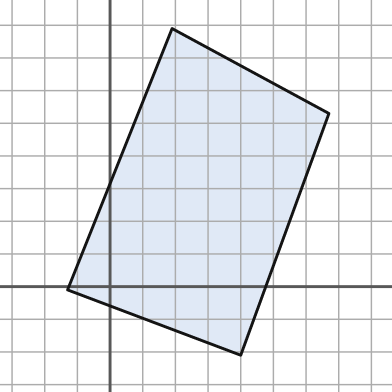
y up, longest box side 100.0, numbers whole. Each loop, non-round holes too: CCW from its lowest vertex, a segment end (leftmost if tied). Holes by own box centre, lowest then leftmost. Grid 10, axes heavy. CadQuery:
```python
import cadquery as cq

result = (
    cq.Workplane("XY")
    .moveTo(40.0, -21.0)
    .lineTo(67.0, 53.0)
    .lineTo(19.0, 79.0)
    .lineTo(-13.0, -1.0)
    .close()
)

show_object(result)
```